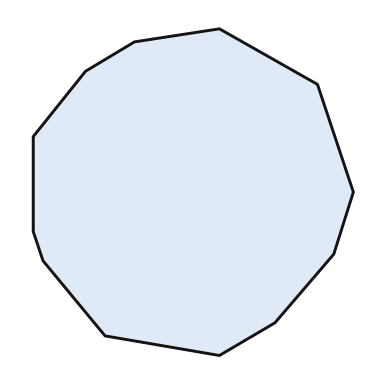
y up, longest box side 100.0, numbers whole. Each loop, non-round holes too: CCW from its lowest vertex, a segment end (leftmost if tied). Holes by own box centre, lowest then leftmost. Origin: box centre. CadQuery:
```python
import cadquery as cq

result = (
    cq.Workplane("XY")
    .moveTo(8.0, -50.0)
    .lineTo(25.0, -40.0)
    .lineTo(43.0, -19.0)
    .lineTo(49.0, 0.0)
    .lineTo(38.0, 33.0)
    .lineTo(8.0, 50.0)
    .lineTo(-18.0, 46.0)
    .lineTo(-33.0, 37.0)
    .lineTo(-49.0, 17.0)
    .lineTo(-49.0, -12.0)
    .lineTo(-46.0, -21.0)
    .lineTo(-27.0, -44.0)
    .close()
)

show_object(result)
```